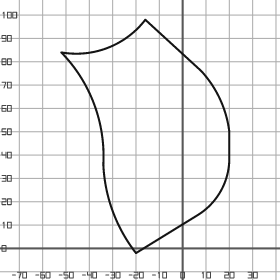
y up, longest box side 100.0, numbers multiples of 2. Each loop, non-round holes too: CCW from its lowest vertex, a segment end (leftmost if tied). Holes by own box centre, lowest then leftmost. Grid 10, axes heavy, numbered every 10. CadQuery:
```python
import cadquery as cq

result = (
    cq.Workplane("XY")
    .moveTo(-20.0, -2.0)
    .lineTo(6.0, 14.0)
    .threePointArc((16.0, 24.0), (20.0, 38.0))
    .lineTo(20.0, 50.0)
    .threePointArc((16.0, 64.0), (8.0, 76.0))
    .lineTo(-16.0, 98.0)
    .threePointArc((-32.0, 86.0), (-52.0, 84.0))
    .threePointArc((-38.0, 62.0), (-34.0, 36.0))
    .threePointArc((-30.0, 16.0), (-20.0, -2.0))
    .close()
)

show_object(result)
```